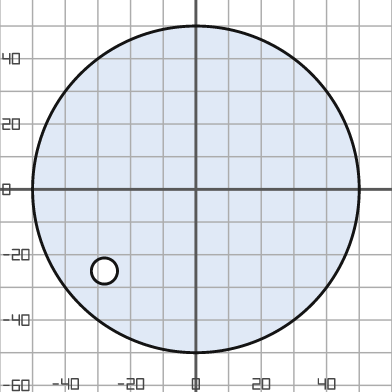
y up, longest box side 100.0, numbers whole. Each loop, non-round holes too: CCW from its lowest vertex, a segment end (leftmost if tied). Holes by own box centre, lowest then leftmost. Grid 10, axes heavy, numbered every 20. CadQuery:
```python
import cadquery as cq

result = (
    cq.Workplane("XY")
    .moveTo(0.0, 0.0)
    .circle(50.0)
    .moveTo(-28.0, -25.0)
    .circle(4.0)
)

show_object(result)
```